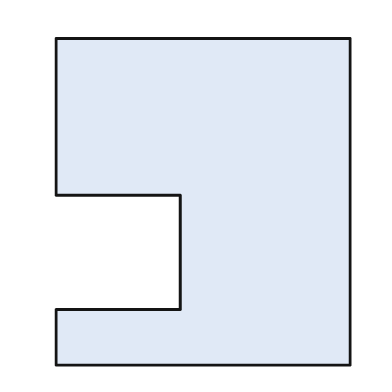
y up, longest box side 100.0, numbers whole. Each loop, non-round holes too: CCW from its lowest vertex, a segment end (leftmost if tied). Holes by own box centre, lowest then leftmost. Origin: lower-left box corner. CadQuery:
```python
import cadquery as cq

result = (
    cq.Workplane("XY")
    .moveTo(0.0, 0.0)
    .lineTo(90.0, 0.0)
    .lineTo(90.0, 100.0)
    .lineTo(0.0, 100.0)
    .lineTo(0.0, 52.0)
    .lineTo(38.0, 52.0)
    .lineTo(38.0, 17.0)
    .lineTo(0.0, 17.0)
    .close()
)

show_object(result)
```